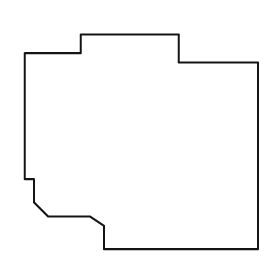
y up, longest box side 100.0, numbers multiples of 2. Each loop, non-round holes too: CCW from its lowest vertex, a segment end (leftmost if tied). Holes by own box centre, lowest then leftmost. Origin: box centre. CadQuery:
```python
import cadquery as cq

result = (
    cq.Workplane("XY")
    .moveTo(-16.0, -46.0)
    .lineTo(50.0, -46.0)
    .lineTo(50.0, 34.0)
    .lineTo(16.0, 34.0)
    .lineTo(16.0, 46.0)
    .lineTo(-26.0, 46.0)
    .lineTo(-26.0, 38.0)
    .lineTo(-50.0, 38.0)
    .lineTo(-50.0, -16.0)
    .lineTo(-46.0, -16.0)
    .lineTo(-46.0, -26.0)
    .lineTo(-40.0, -32.0)
    .lineTo(-22.0, -32.0)
    .lineTo(-16.0, -36.0)
    .close()
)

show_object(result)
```